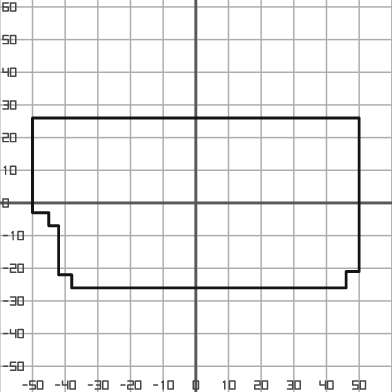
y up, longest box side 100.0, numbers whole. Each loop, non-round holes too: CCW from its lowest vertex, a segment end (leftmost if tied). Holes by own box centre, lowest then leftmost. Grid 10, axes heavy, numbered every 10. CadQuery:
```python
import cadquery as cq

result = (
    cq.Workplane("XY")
    .moveTo(-38.0, -26.0)
    .lineTo(46.0, -26.0)
    .lineTo(46.0, -21.0)
    .lineTo(50.0, -21.0)
    .lineTo(50.0, 26.0)
    .lineTo(-50.0, 26.0)
    .lineTo(-50.0, -3.0)
    .lineTo(-45.0, -3.0)
    .lineTo(-45.0, -7.0)
    .lineTo(-42.0, -7.0)
    .lineTo(-42.0, -22.0)
    .lineTo(-38.0, -22.0)
    .close()
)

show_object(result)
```